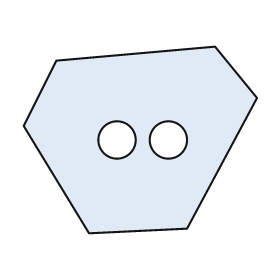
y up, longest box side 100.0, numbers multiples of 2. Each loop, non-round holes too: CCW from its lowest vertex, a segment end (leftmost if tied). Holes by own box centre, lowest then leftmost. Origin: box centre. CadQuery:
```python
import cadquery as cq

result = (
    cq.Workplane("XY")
    .moveTo(-22.0, -40.0)
    .lineTo(20.0, -38.0)
    .lineTo(50.0, 18.0)
    .lineTo(32.0, 40.0)
    .lineTo(-36.0, 34.0)
    .lineTo(-50.0, 6.0)
    .close()
    .moveTo(-10.0, 0.0)
    .circle(8.0)
    .moveTo(12.0, 0.0)
    .circle(8.0)
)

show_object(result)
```